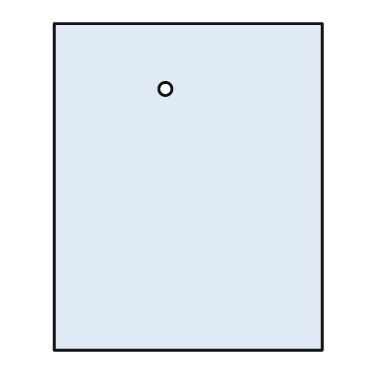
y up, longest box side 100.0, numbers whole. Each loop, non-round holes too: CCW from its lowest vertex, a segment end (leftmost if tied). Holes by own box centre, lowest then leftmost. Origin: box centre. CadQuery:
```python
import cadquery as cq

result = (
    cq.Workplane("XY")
    .moveTo(-41.0, -50.0)
    .lineTo(41.0, -50.0)
    .lineTo(41.0, 50.0)
    .lineTo(-41.0, 50.0)
    .close()
    .moveTo(-7.0, 30.0)
    .circle(2.0)
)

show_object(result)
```